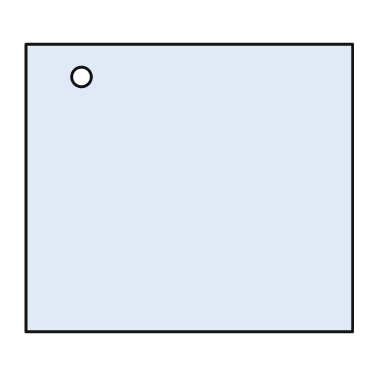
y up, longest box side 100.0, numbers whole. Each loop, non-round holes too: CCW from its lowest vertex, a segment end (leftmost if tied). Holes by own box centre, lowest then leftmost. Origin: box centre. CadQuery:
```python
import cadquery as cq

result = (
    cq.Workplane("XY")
    .moveTo(-50.0, -44.0)
    .lineTo(50.0, -44.0)
    .lineTo(50.0, 44.0)
    .lineTo(-50.0, 44.0)
    .close()
    .moveTo(-33.0, 34.0)
    .circle(3.0)
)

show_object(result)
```